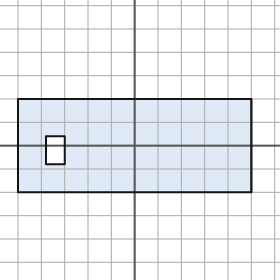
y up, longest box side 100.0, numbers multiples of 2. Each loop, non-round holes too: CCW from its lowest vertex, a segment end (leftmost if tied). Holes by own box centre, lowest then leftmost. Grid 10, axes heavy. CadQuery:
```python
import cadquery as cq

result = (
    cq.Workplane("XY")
    .moveTo(-50.0, -20.0)
    .lineTo(50.0, -20.0)
    .lineTo(50.0, 20.0)
    .lineTo(-50.0, 20.0)
    .close()
    .moveTo(-38.0, -8.0)
    .lineTo(-30.0, -8.0)
    .lineTo(-30.0, 4.0)
    .lineTo(-38.0, 4.0)
    .close()
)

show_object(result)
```